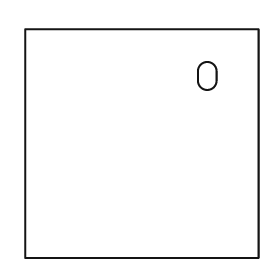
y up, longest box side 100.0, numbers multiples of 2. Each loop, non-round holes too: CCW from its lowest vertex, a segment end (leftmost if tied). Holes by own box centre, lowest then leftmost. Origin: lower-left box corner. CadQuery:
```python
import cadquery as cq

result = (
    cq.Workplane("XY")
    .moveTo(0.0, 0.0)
    .lineTo(100.0, 0.0)
    .lineTo(100.0, 98.0)
    .lineTo(0.0, 98.0)
    .close()
    .moveTo(74.0, 76.0)
    .threePointArc((78.0, 72.0), (82.0, 76.0))
    .lineTo(82.0, 80.0)
    .threePointArc((78.0, 84.0), (74.0, 80.0))
    .close()
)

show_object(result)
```